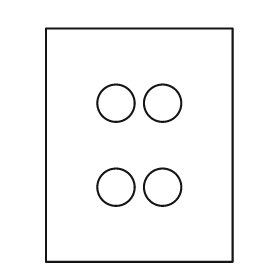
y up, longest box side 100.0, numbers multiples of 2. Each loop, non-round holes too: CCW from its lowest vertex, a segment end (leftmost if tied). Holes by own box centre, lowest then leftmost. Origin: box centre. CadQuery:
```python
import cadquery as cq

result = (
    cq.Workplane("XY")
    .moveTo(-40.0, -50.0)
    .lineTo(40.0, -50.0)
    .lineTo(40.0, 50.0)
    .lineTo(-40.0, 50.0)
    .close()
    .moveTo(-10.0, -18.0)
    .circle(8.0)
    .moveTo(10.0, -18.0)
    .circle(8.0)
    .moveTo(-10.0, 18.0)
    .circle(8.0)
    .moveTo(10.0, 18.0)
    .circle(8.0)
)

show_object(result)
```